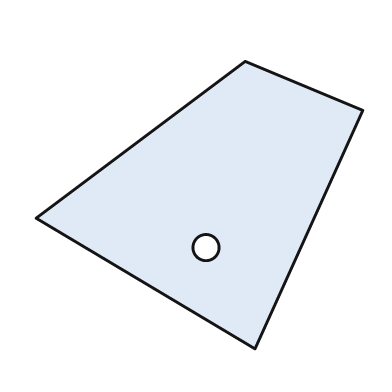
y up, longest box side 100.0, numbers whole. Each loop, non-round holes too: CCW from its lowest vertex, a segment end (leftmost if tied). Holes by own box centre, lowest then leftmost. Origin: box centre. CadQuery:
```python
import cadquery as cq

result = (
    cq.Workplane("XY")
    .moveTo(17.0, -44.0)
    .lineTo(50.0, 29.0)
    .lineTo(14.0, 44.0)
    .lineTo(-50.0, -4.0)
    .close()
    .moveTo(2.0, -13.0)
    .circle(4.0)
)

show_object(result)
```